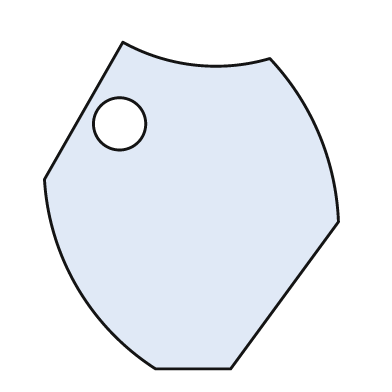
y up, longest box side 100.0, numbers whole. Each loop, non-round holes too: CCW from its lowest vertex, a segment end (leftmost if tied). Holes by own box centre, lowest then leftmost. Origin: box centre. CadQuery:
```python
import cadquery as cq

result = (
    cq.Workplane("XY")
    .moveTo(-11.0, -50.0)
    .lineTo(12.0, -50.0)
    .lineTo(45.0, -5.0)
    .threePointArc((39.0, 22.0), (24.0, 45.0))
    .threePointArc((1.0, 43.0), (-21.0, 50.0))
    .lineTo(-45.0, 8.0)
    .threePointArc((-35.0, -25.0), (-11.0, -50.0))
    .close()
    .moveTo(-22.0, 25.0)
    .circle(8.0)
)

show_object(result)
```